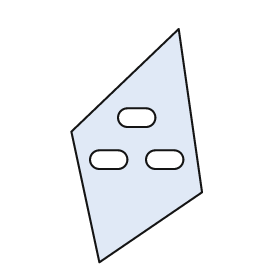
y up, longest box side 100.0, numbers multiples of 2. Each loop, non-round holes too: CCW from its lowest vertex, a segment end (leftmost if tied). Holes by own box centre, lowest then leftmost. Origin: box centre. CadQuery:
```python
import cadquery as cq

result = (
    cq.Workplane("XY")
    .moveTo(-16.0, -50.0)
    .lineTo(28.0, -20.0)
    .lineTo(18.0, 50.0)
    .lineTo(-28.0, 6.0)
    .close()
    .moveTo(-16.0, -10.0)
    .lineTo(-8.0, -10.0)
    .threePointArc((-4.0, -6.0), (-8.0, -2.0))
    .lineTo(-16.0, -2.0)
    .threePointArc((-20.0, -6.0), (-16.0, -10.0))
    .close()
    .moveTo(8.0, -10.0)
    .lineTo(16.0, -10.0)
    .threePointArc((20.0, -6.0), (16.0, -2.0))
    .lineTo(8.0, -2.0)
    .threePointArc((4.0, -6.0), (8.0, -10.0))
    .close()
    .moveTo(-4.0, 8.0)
    .lineTo(4.0, 8.0)
    .threePointArc((8.0, 12.0), (4.0, 16.0))
    .lineTo(-4.0, 16.0)
    .threePointArc((-8.0, 12.0), (-4.0, 8.0))
    .close()
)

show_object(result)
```